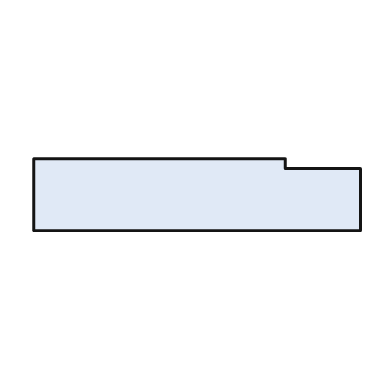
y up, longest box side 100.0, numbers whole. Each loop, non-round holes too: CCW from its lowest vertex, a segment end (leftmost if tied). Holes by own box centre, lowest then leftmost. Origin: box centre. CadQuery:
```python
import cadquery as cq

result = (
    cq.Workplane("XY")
    .moveTo(-50.0, -11.0)
    .lineTo(50.0, -11.0)
    .lineTo(50.0, 8.0)
    .lineTo(27.0, 8.0)
    .lineTo(27.0, 11.0)
    .lineTo(-50.0, 11.0)
    .close()
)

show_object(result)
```